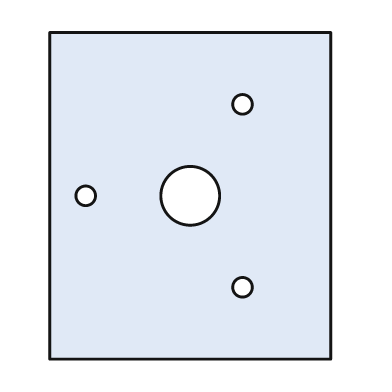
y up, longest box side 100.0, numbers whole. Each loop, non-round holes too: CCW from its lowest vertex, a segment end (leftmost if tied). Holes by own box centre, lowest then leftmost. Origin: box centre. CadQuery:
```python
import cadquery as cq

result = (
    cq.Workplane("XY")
    .moveTo(-43.0, -50.0)
    .lineTo(43.0, -50.0)
    .lineTo(43.0, 50.0)
    .lineTo(-43.0, 50.0)
    .close()
    .moveTo(16.0, -28.0)
    .circle(3.0)
    .moveTo(-32.0, 0.0)
    .circle(3.0)
    .moveTo(0.0, 0.0)
    .circle(9.0)
    .moveTo(16.0, 28.0)
    .circle(3.0)
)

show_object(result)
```